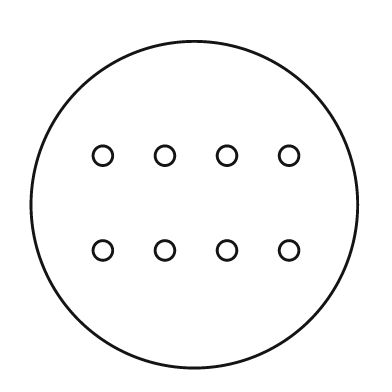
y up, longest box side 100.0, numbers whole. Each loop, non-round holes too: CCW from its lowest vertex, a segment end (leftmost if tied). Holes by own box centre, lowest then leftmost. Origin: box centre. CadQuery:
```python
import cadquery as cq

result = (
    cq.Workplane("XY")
    .moveTo(0.0, 0.0)
    .circle(50.0)
    .moveTo(-28.0, -14.0)
    .circle(3.0)
    .moveTo(-9.0, -14.0)
    .circle(3.0)
    .moveTo(10.0, -14.0)
    .circle(3.0)
    .moveTo(29.0, -14.0)
    .circle(3.0)
    .moveTo(-28.0, 15.0)
    .circle(3.0)
    .moveTo(-9.0, 15.0)
    .circle(3.0)
    .moveTo(10.0, 15.0)
    .circle(3.0)
    .moveTo(29.0, 15.0)
    .circle(3.0)
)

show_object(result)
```